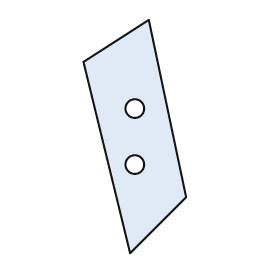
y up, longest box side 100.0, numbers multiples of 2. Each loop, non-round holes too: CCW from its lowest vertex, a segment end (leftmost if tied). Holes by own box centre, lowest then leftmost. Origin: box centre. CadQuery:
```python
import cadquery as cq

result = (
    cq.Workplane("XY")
    .moveTo(-2.0, -50.0)
    .lineTo(22.0, -26.0)
    .lineTo(6.0, 50.0)
    .lineTo(-22.0, 32.0)
    .close()
    .moveTo(0.0, -12.0)
    .circle(4.0)
    .moveTo(0.0, 12.0)
    .circle(4.0)
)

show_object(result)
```